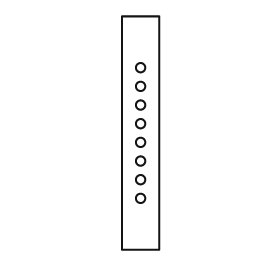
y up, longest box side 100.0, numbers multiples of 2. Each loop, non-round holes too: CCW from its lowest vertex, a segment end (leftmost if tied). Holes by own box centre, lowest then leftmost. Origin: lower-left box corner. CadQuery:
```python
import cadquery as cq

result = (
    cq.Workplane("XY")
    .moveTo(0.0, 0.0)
    .lineTo(16.0, 0.0)
    .lineTo(16.0, 100.0)
    .lineTo(0.0, 100.0)
    .close()
    .moveTo(8.0, 22.0)
    .circle(2.0)
    .moveTo(8.0, 30.0)
    .circle(2.0)
    .moveTo(8.0, 38.0)
    .circle(2.0)
    .moveTo(8.0, 46.0)
    .circle(2.0)
    .moveTo(8.0, 54.0)
    .circle(2.0)
    .moveTo(8.0, 62.0)
    .circle(2.0)
    .moveTo(8.0, 70.0)
    .circle(2.0)
    .moveTo(8.0, 78.0)
    .circle(2.0)
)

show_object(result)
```